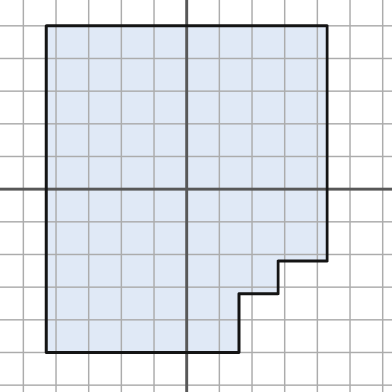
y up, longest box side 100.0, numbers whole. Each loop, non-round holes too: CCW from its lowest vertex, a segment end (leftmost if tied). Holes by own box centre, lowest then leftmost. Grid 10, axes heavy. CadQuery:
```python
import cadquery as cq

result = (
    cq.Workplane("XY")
    .moveTo(-43.0, -50.0)
    .lineTo(16.0, -50.0)
    .lineTo(16.0, -32.0)
    .lineTo(28.0, -32.0)
    .lineTo(28.0, -22.0)
    .lineTo(43.0, -22.0)
    .lineTo(43.0, 50.0)
    .lineTo(-43.0, 50.0)
    .close()
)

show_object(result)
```